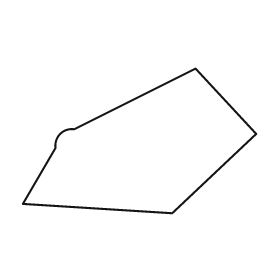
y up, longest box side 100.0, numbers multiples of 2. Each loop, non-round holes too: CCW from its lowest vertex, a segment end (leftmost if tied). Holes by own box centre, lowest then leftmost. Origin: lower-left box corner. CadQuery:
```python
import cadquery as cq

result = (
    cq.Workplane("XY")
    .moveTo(64.0, 0.0)
    .lineTo(100.0, 34.0)
    .lineTo(74.0, 62.0)
    .lineTo(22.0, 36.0)
    .threePointArc((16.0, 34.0), (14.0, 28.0))
    .lineTo(0.0, 4.0)
    .close()
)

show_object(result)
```